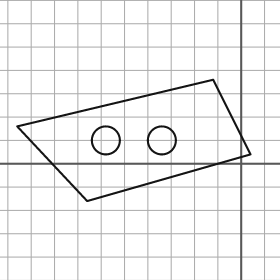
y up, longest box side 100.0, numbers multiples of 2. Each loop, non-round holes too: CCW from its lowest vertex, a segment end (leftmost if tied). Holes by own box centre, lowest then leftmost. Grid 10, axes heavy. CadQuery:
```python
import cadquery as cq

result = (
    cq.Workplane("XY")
    .moveTo(-66.0, -16.0)
    .lineTo(4.0, 4.0)
    .lineTo(-12.0, 36.0)
    .lineTo(-96.0, 16.0)
    .close()
    .moveTo(-58.0, 10.0)
    .circle(6.0)
    .moveTo(-34.0, 10.0)
    .circle(6.0)
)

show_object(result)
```